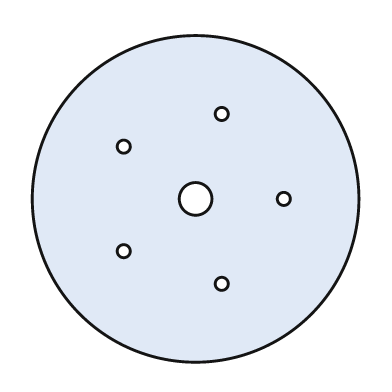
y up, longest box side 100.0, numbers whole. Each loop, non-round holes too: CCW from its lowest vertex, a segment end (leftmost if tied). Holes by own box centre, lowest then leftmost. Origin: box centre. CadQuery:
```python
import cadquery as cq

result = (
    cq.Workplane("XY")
    .moveTo(0.0, 0.0)
    .circle(50.0)
    .moveTo(8.0, -26.0)
    .circle(2.0)
    .moveTo(-22.0, -16.0)
    .circle(2.0)
    .moveTo(0.0, 0.0)
    .circle(5.0)
    .moveTo(27.0, 0.0)
    .circle(2.0)
    .moveTo(-22.0, 16.0)
    .circle(2.0)
    .moveTo(8.0, 26.0)
    .circle(2.0)
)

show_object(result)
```